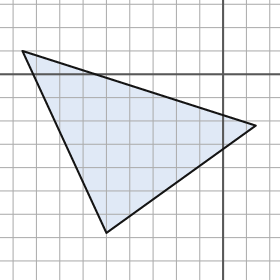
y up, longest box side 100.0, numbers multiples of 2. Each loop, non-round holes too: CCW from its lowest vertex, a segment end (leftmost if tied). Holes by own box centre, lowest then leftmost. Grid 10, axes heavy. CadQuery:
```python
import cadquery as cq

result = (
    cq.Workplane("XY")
    .moveTo(-50.0, -68.0)
    .lineTo(14.0, -22.0)
    .lineTo(-86.0, 10.0)
    .close()
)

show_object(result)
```